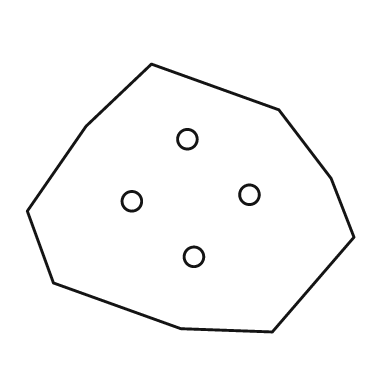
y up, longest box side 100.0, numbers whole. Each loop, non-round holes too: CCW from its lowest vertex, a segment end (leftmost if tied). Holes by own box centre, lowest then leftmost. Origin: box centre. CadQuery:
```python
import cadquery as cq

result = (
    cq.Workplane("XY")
    .moveTo(25.0, -41.0)
    .lineTo(50.0, -12.0)
    .lineTo(43.0, 6.0)
    .lineTo(27.0, 27.0)
    .lineTo(-12.0, 41.0)
    .lineTo(-32.0, 22.0)
    .lineTo(-50.0, -4.0)
    .lineTo(-42.0, -26.0)
    .lineTo(-3.0, -40.0)
    .close()
    .moveTo(1.0, -18.0)
    .circle(3.0)
    .moveTo(-18.0, -1.0)
    .circle(3.0)
    .moveTo(18.0, 1.0)
    .circle(3.0)
    .moveTo(-1.0, 18.0)
    .circle(3.0)
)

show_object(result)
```